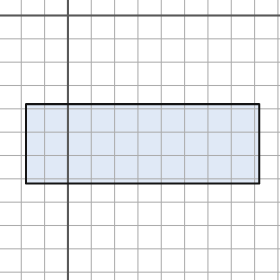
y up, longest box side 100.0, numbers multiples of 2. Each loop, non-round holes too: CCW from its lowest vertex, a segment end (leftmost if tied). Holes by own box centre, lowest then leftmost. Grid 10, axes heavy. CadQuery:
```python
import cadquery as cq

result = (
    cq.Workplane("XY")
    .moveTo(-18.0, -72.0)
    .lineTo(82.0, -72.0)
    .lineTo(82.0, -38.0)
    .lineTo(-18.0, -38.0)
    .close()
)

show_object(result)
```